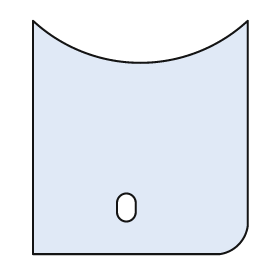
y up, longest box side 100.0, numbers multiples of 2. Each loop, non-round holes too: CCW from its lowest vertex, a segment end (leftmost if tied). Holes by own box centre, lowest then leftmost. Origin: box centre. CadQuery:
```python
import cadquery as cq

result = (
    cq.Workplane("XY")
    .moveTo(-46.0, -50.0)
    .lineTo(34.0, -50.0)
    .threePointArc((42.0, -46.0), (46.0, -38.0))
    .lineTo(46.0, 50.0)
    .threePointArc((0.0, 32.0), (-46.0, 50.0))
    .close()
    .moveTo(-10.0, -32.0)
    .threePointArc((-6.0, -36.0), (-2.0, -32.0))
    .lineTo(-2.0, -28.0)
    .threePointArc((-6.0, -24.0), (-10.0, -28.0))
    .close()
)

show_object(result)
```